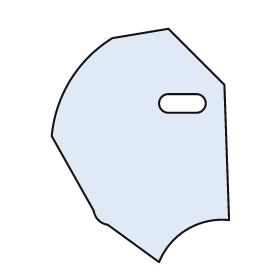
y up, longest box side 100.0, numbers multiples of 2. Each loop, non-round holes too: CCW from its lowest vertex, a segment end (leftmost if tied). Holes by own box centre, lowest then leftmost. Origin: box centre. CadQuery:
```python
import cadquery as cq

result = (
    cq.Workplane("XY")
    .moveTo(8.0, -50.0)
    .threePointArc((20.0, -36.0), (38.0, -32.0))
    .lineTo(36.0, 26.0)
    .lineTo(12.0, 50.0)
    .lineTo(-12.0, 46.0)
    .threePointArc((-30.0, 28.0), (-38.0, 4.0))
    .lineTo(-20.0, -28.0)
    .threePointArc((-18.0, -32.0), (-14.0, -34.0))
    .close()
    .moveTo(12.0, 14.0)
    .lineTo(24.0, 14.0)
    .threePointArc((28.0, 18.0), (24.0, 22.0))
    .lineTo(12.0, 22.0)
    .threePointArc((8.0, 18.0), (12.0, 14.0))
    .close()
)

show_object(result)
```